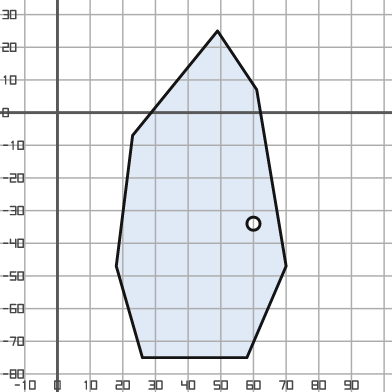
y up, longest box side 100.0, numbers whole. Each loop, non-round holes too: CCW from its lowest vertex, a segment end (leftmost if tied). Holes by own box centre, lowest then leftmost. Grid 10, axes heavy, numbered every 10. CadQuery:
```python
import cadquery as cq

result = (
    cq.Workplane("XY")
    .moveTo(26.0, -75.0)
    .lineTo(58.0, -75.0)
    .lineTo(70.0, -47.0)
    .lineTo(61.0, 7.0)
    .lineTo(49.0, 25.0)
    .lineTo(23.0, -7.0)
    .lineTo(18.0, -47.0)
    .close()
    .moveTo(60.0, -34.0)
    .circle(2.0)
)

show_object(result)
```